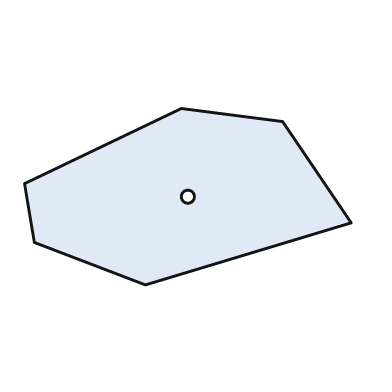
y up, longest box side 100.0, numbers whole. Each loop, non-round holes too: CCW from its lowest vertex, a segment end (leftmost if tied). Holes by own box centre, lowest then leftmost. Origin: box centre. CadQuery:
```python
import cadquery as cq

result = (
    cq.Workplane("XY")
    .moveTo(-13.0, -27.0)
    .lineTo(50.0, -8.0)
    .lineTo(29.0, 23.0)
    .lineTo(-2.0, 27.0)
    .lineTo(-50.0, 4.0)
    .lineTo(-47.0, -14.0)
    .close()
    .moveTo(0.0, 0.0)
    .circle(2.0)
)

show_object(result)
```